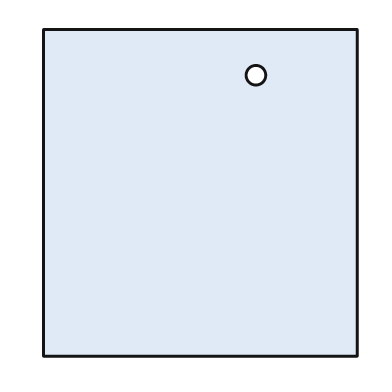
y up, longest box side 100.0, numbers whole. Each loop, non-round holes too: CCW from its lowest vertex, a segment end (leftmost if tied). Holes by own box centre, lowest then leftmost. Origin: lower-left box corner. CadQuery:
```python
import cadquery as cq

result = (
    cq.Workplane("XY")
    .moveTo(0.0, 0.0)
    .lineTo(96.0, 0.0)
    .lineTo(96.0, 100.0)
    .lineTo(0.0, 100.0)
    .close()
    .moveTo(65.0, 86.0)
    .circle(3.0)
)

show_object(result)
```